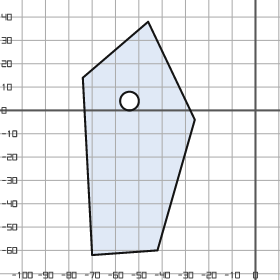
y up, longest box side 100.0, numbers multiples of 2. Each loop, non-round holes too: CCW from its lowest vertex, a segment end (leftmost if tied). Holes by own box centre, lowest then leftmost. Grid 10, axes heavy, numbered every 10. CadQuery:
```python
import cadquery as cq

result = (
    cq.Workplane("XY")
    .moveTo(-70.0, -62.0)
    .lineTo(-42.0, -60.0)
    .lineTo(-26.0, -4.0)
    .lineTo(-46.0, 38.0)
    .lineTo(-74.0, 14.0)
    .close()
    .moveTo(-54.0, 4.0)
    .circle(4.0)
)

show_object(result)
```